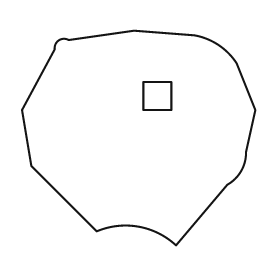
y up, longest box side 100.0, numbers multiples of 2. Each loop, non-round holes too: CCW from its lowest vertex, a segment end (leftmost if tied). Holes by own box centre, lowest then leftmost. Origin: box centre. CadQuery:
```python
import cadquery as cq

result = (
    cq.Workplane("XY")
    .moveTo(16.0, -46.0)
    .lineTo(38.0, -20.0)
    .threePointArc((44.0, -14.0), (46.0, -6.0))
    .lineTo(50.0, 12.0)
    .lineTo(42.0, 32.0)
    .threePointArc((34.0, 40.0), (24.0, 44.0))
    .lineTo(-2.0, 46.0)
    .lineTo(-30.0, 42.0)
    .threePointArc((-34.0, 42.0), (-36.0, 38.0))
    .lineTo(-50.0, 12.0)
    .lineTo(-46.0, -12.0)
    .lineTo(-18.0, -40.0)
    .threePointArc((0.0, -38.0), (16.0, -46.0))
    .close()
    .moveTo(2.0, 12.0)
    .lineTo(14.0, 12.0)
    .lineTo(14.0, 24.0)
    .lineTo(2.0, 24.0)
    .close()
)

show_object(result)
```